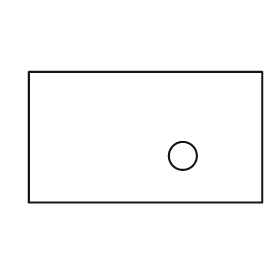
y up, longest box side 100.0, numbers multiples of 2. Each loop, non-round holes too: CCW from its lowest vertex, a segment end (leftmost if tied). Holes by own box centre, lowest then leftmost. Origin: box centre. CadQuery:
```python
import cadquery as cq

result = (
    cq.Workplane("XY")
    .moveTo(-50.0, -28.0)
    .lineTo(50.0, -28.0)
    .lineTo(50.0, 28.0)
    .lineTo(-50.0, 28.0)
    .close()
    .moveTo(16.0, -8.0)
    .circle(6.0)
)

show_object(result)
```